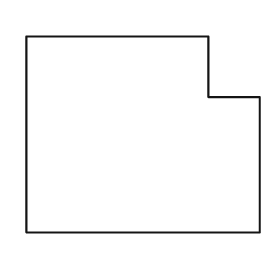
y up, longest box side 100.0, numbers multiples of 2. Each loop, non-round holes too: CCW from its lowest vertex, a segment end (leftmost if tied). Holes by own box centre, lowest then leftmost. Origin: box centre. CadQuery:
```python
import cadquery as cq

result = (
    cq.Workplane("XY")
    .moveTo(-50.0, -42.0)
    .lineTo(50.0, -42.0)
    .lineTo(50.0, 16.0)
    .lineTo(28.0, 16.0)
    .lineTo(28.0, 42.0)
    .lineTo(-50.0, 42.0)
    .close()
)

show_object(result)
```